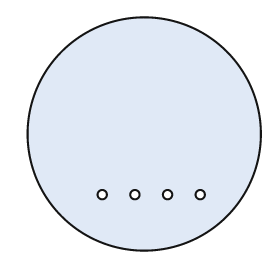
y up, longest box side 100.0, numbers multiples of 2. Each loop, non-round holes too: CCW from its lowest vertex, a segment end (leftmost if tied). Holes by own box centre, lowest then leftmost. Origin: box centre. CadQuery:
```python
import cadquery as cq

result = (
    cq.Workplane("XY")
    .moveTo(0.0, 0.0)
    .circle(50.0)
    .moveTo(-18.0, -26.0)
    .circle(2.0)
    .moveTo(-4.0, -26.0)
    .circle(2.0)
    .moveTo(10.0, -26.0)
    .circle(2.0)
    .moveTo(24.0, -26.0)
    .circle(2.0)
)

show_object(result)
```